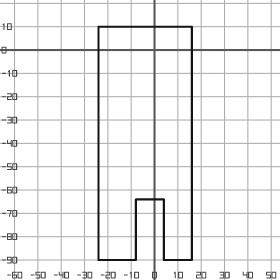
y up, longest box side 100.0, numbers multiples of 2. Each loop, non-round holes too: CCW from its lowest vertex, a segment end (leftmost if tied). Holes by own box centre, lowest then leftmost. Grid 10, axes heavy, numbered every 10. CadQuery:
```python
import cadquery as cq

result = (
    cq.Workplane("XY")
    .moveTo(-24.0, -90.0)
    .lineTo(-8.0, -90.0)
    .lineTo(-8.0, -64.0)
    .lineTo(4.0, -64.0)
    .lineTo(4.0, -90.0)
    .lineTo(16.0, -90.0)
    .lineTo(16.0, 10.0)
    .lineTo(-24.0, 10.0)
    .close()
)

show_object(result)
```